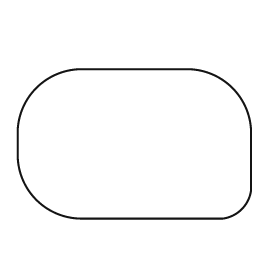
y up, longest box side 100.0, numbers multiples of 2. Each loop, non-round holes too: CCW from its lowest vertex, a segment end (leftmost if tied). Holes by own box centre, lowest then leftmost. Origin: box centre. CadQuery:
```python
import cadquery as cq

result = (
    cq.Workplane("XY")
    .moveTo(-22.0, -32.0)
    .lineTo(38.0, -32.0)
    .threePointArc((46.0, -28.0), (50.0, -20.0))
    .lineTo(50.0, 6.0)
    .threePointArc((42.0, 24.0), (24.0, 32.0))
    .lineTo(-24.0, 32.0)
    .threePointArc((-42.0, 24.0), (-50.0, 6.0))
    .lineTo(-50.0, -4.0)
    .threePointArc((-42.0, -24.0), (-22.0, -32.0))
    .close()
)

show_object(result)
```